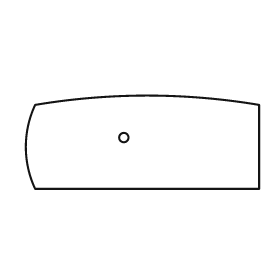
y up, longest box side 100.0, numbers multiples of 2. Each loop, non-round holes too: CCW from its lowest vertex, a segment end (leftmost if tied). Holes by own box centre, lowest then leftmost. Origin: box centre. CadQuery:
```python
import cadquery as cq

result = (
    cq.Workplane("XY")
    .moveTo(-46.0, -20.0)
    .lineTo(50.0, -20.0)
    .lineTo(50.0, 16.0)
    .threePointArc((2.0, 20.0), (-46.0, 16.0))
    .threePointArc((-50.0, -2.0), (-46.0, -20.0))
    .close()
    .moveTo(-8.0, 2.0)
    .circle(2.0)
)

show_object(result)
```